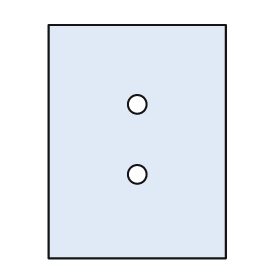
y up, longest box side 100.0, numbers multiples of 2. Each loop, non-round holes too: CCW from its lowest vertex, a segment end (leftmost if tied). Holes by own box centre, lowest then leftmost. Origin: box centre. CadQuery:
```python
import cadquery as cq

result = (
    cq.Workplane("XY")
    .moveTo(-38.0, -50.0)
    .lineTo(38.0, -50.0)
    .lineTo(38.0, 50.0)
    .lineTo(-38.0, 50.0)
    .close()
    .moveTo(0.0, -14.0)
    .circle(4.0)
    .moveTo(0.0, 16.0)
    .circle(4.0)
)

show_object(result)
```